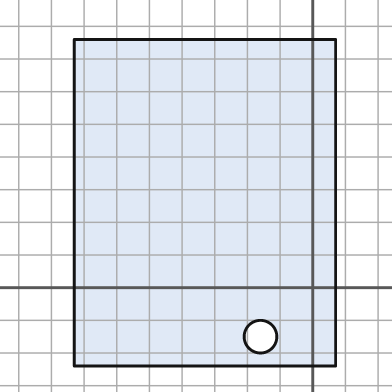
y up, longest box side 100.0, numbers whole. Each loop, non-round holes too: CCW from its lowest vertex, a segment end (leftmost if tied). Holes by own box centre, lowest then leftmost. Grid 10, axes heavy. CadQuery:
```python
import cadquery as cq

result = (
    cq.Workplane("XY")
    .moveTo(-73.0, -24.0)
    .lineTo(7.0, -24.0)
    .lineTo(7.0, 76.0)
    .lineTo(-73.0, 76.0)
    .close()
    .moveTo(-16.0, -15.0)
    .circle(5.0)
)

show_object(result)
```